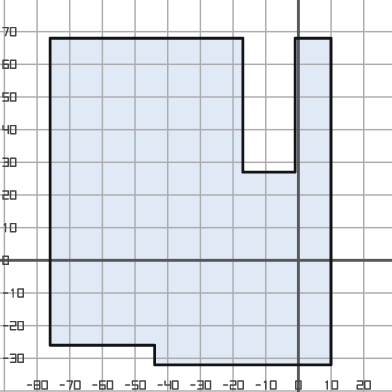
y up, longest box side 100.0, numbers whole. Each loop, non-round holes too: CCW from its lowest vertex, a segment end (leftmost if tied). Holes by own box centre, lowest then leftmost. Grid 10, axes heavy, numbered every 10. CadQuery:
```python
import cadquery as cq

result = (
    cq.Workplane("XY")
    .moveTo(-44.0, -32.0)
    .lineTo(10.0, -32.0)
    .lineTo(10.0, 68.0)
    .lineTo(-1.0, 68.0)
    .lineTo(-1.0, 27.0)
    .lineTo(-17.0, 27.0)
    .lineTo(-17.0, 68.0)
    .lineTo(-76.0, 68.0)
    .lineTo(-76.0, -26.0)
    .lineTo(-44.0, -26.0)
    .close()
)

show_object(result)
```